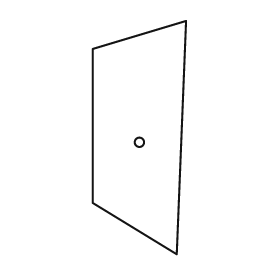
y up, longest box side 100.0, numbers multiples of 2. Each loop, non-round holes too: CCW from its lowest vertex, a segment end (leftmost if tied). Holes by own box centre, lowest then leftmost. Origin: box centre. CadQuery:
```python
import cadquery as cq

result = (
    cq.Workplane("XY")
    .moveTo(16.0, -50.0)
    .lineTo(20.0, 50.0)
    .lineTo(-20.0, 38.0)
    .lineTo(-20.0, -28.0)
    .close()
    .moveTo(0.0, -2.0)
    .circle(2.0)
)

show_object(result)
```